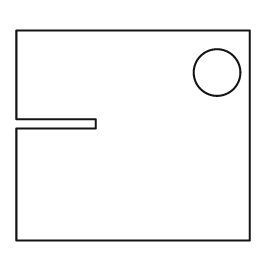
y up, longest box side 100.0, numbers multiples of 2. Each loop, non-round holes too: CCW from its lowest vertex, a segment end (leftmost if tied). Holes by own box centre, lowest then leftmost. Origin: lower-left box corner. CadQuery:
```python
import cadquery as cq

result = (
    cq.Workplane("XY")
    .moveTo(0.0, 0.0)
    .lineTo(100.0, 0.0)
    .lineTo(100.0, 90.0)
    .lineTo(0.0, 90.0)
    .lineTo(0.0, 52.0)
    .lineTo(34.0, 52.0)
    .lineTo(34.0, 48.0)
    .lineTo(0.0, 48.0)
    .close()
    .moveTo(86.0, 72.0)
    .circle(10.0)
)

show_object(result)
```